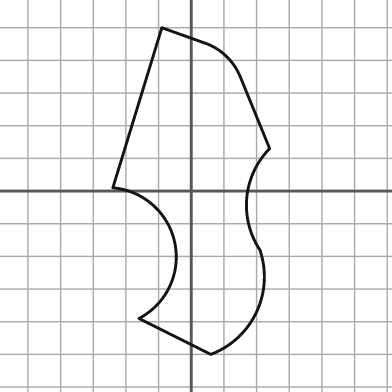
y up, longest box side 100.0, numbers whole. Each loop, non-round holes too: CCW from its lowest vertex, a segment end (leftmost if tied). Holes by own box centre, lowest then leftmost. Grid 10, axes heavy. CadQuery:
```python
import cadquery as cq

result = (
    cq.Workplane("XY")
    .moveTo(6.0, -50.0)
    .threePointArc((20.0, -37.0), (21.0, -18.0))
    .threePointArc((17.0, -2.0), (24.0, 13.0))
    .lineTo(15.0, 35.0)
    .threePointArc((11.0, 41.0), (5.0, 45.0))
    .lineTo(-9.0, 50.0)
    .lineTo(-24.0, 1.0)
    .threePointArc((-5.0, -16.0), (-16.0, -39.0))
    .close()
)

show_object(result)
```